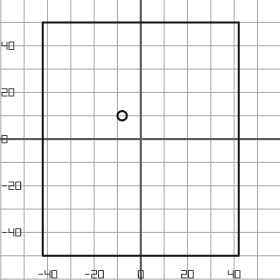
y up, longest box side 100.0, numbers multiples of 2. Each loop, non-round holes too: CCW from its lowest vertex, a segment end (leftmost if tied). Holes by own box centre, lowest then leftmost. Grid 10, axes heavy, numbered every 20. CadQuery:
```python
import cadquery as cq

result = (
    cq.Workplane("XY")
    .moveTo(-42.0, -50.0)
    .lineTo(42.0, -50.0)
    .lineTo(42.0, 50.0)
    .lineTo(-42.0, 50.0)
    .close()
    .moveTo(-8.0, 10.0)
    .circle(2.0)
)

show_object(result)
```